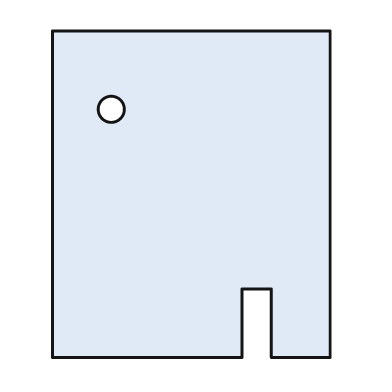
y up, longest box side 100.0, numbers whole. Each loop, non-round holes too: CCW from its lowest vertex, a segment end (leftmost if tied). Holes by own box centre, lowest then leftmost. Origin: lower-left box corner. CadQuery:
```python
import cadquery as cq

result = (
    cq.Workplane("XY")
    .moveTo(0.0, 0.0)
    .lineTo(58.0, 0.0)
    .lineTo(58.0, 21.0)
    .lineTo(67.0, 21.0)
    .lineTo(67.0, 0.0)
    .lineTo(85.0, 0.0)
    .lineTo(85.0, 100.0)
    .lineTo(0.0, 100.0)
    .close()
    .moveTo(18.0, 76.0)
    .circle(4.0)
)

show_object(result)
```